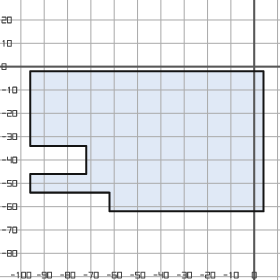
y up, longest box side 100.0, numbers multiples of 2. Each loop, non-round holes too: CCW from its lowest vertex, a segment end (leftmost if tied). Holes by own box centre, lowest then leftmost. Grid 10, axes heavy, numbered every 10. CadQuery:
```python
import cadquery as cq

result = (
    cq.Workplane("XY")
    .moveTo(-62.0, -62.0)
    .lineTo(4.0, -62.0)
    .lineTo(4.0, -2.0)
    .lineTo(-96.0, -2.0)
    .lineTo(-96.0, -34.0)
    .lineTo(-72.0, -34.0)
    .lineTo(-72.0, -46.0)
    .lineTo(-96.0, -46.0)
    .lineTo(-96.0, -54.0)
    .lineTo(-62.0, -54.0)
    .close()
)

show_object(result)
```